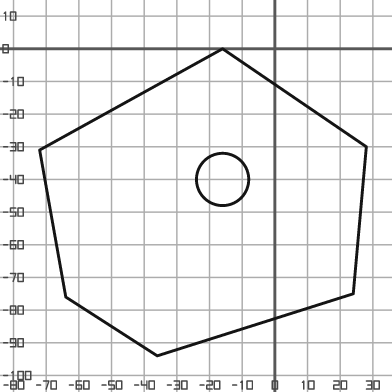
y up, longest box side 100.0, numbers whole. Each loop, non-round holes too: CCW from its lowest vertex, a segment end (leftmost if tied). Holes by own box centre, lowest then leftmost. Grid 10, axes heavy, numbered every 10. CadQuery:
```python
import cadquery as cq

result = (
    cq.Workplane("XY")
    .moveTo(-36.0, -94.0)
    .lineTo(24.0, -75.0)
    .lineTo(28.0, -30.0)
    .lineTo(-16.0, 0.0)
    .lineTo(-72.0, -31.0)
    .lineTo(-64.0, -76.0)
    .close()
    .moveTo(-16.0, -40.0)
    .circle(8.0)
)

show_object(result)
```